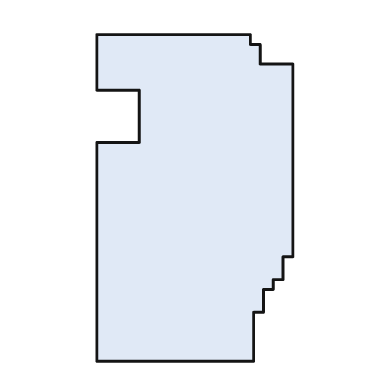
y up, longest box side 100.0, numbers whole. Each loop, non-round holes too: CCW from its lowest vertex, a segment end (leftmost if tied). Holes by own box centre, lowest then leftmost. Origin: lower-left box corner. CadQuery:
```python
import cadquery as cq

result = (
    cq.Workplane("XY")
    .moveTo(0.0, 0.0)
    .lineTo(48.0, 0.0)
    .lineTo(48.0, 15.0)
    .lineTo(51.0, 15.0)
    .lineTo(51.0, 22.0)
    .lineTo(54.0, 22.0)
    .lineTo(54.0, 25.0)
    .lineTo(57.0, 25.0)
    .lineTo(57.0, 32.0)
    .lineTo(60.0, 32.0)
    .lineTo(60.0, 91.0)
    .lineTo(50.0, 91.0)
    .lineTo(50.0, 97.0)
    .lineTo(47.0, 97.0)
    .lineTo(47.0, 100.0)
    .lineTo(0.0, 100.0)
    .lineTo(0.0, 83.0)
    .lineTo(13.0, 83.0)
    .lineTo(13.0, 67.0)
    .lineTo(0.0, 67.0)
    .close()
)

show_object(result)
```